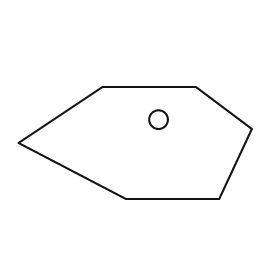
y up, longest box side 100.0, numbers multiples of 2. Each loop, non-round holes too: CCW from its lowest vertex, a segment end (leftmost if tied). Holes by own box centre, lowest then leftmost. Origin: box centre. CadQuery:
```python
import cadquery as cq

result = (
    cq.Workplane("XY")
    .moveTo(-4.0, -24.0)
    .lineTo(36.0, -24.0)
    .lineTo(50.0, 6.0)
    .lineTo(26.0, 24.0)
    .lineTo(-14.0, 24.0)
    .lineTo(-50.0, 0.0)
    .close()
    .moveTo(10.0, 10.0)
    .circle(4.0)
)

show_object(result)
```